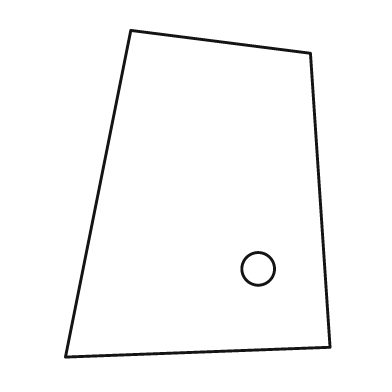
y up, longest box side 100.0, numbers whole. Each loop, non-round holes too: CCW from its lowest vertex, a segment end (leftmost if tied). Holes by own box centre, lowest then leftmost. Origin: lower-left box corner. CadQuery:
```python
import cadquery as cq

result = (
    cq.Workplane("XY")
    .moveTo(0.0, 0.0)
    .lineTo(81.0, 3.0)
    .lineTo(75.0, 93.0)
    .lineTo(20.0, 100.0)
    .close()
    .moveTo(59.0, 27.0)
    .circle(5.0)
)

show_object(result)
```